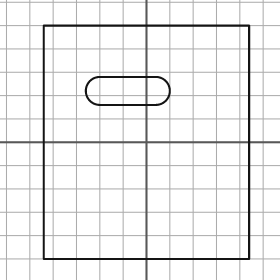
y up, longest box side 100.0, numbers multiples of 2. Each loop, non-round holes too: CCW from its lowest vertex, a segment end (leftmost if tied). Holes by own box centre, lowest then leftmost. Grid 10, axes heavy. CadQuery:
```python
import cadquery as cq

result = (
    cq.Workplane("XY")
    .moveTo(-44.0, -50.0)
    .lineTo(44.0, -50.0)
    .lineTo(44.0, 50.0)
    .lineTo(-44.0, 50.0)
    .close()
    .moveTo(-20.0, 16.0)
    .lineTo(4.0, 16.0)
    .threePointArc((10.0, 22.0), (4.0, 28.0))
    .lineTo(-20.0, 28.0)
    .threePointArc((-26.0, 22.0), (-20.0, 16.0))
    .close()
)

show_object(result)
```